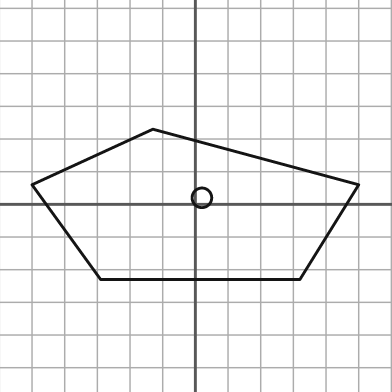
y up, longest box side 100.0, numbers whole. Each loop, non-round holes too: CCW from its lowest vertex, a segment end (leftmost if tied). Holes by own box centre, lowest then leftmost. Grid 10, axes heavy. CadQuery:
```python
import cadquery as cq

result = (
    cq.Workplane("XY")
    .moveTo(-29.0, -23.0)
    .lineTo(32.0, -23.0)
    .lineTo(50.0, 6.0)
    .lineTo(-13.0, 23.0)
    .lineTo(-50.0, 6.0)
    .close()
    .moveTo(2.0, 2.0)
    .circle(3.0)
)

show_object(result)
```